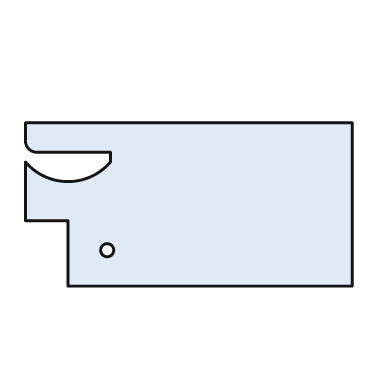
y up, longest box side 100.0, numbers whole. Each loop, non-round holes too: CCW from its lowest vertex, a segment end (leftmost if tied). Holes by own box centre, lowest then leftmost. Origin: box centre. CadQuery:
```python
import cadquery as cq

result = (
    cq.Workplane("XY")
    .moveTo(-37.0, -25.0)
    .lineTo(50.0, -25.0)
    .lineTo(50.0, 25.0)
    .lineTo(-50.0, 25.0)
    .lineTo(-50.0, 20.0)
    .threePointArc((-49.0, 17.0), (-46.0, 16.0))
    .lineTo(-24.0, 16.0)
    .lineTo(-24.0, 13.0)
    .threePointArc((-37.0, 7.0), (-50.0, 13.0))
    .lineTo(-50.0, -5.0)
    .lineTo(-37.0, -5.0)
    .close()
    .moveTo(-25.0, -14.0)
    .circle(2.0)
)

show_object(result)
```